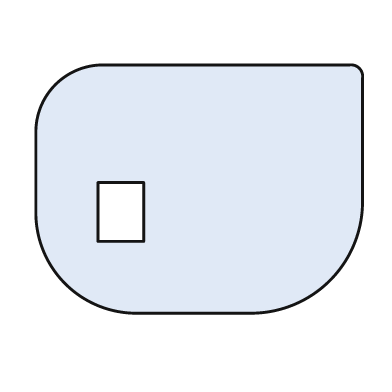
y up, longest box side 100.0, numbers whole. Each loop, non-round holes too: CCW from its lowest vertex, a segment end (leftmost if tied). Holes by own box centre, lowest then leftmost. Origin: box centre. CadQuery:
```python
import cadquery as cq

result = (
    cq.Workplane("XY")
    .moveTo(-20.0, -38.0)
    .lineTo(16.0, -38.0)
    .threePointArc((40.0, -28.0), (50.0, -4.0))
    .lineTo(50.0, 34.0)
    .threePointArc((49.0, 37.0), (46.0, 38.0))
    .lineTo(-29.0, 38.0)
    .threePointArc((-44.0, 32.0), (-50.0, 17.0))
    .lineTo(-50.0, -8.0)
    .threePointArc((-41.0, -29.0), (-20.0, -38.0))
    .close()
    .moveTo(-31.0, -16.0)
    .lineTo(-17.0, -16.0)
    .lineTo(-17.0, 2.0)
    .lineTo(-31.0, 2.0)
    .close()
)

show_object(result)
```